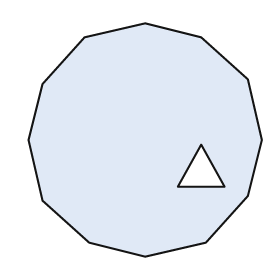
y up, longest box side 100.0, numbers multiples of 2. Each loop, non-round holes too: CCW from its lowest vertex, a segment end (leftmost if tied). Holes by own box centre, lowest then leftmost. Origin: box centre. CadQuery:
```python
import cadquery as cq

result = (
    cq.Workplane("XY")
    .moveTo(0.0, -50.0)
    .lineTo(26.0, -44.0)
    .lineTo(44.0, -24.0)
    .lineTo(50.0, 0.0)
    .lineTo(44.0, 26.0)
    .lineTo(24.0, 44.0)
    .lineTo(0.0, 50.0)
    .lineTo(-26.0, 44.0)
    .lineTo(-44.0, 24.0)
    .lineTo(-50.0, 0.0)
    .lineTo(-44.0, -26.0)
    .lineTo(-24.0, -44.0)
    .close()
    .moveTo(14.0, -20.0)
    .lineTo(34.0, -20.0)
    .lineTo(24.0, -2.0)
    .close()
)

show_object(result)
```